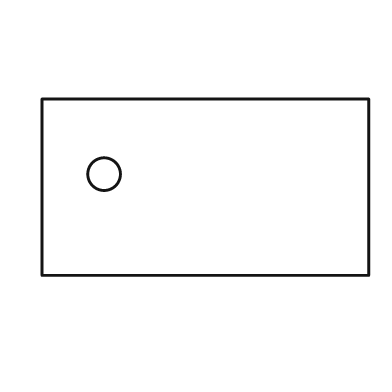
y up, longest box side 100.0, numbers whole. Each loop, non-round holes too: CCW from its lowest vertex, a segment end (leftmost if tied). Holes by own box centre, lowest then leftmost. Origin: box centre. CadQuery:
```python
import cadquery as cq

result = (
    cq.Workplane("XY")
    .moveTo(-50.0, -27.0)
    .lineTo(50.0, -27.0)
    .lineTo(50.0, 27.0)
    .lineTo(-50.0, 27.0)
    .close()
    .moveTo(-31.0, 4.0)
    .circle(5.0)
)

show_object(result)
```